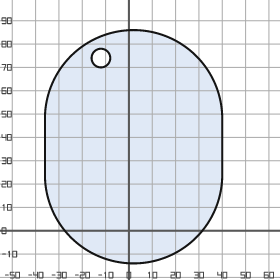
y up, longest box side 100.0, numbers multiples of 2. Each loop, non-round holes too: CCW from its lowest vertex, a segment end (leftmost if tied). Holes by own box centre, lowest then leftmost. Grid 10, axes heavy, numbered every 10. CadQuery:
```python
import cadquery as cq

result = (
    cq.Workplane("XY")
    .moveTo(-36.0, 24.0)
    .threePointArc((2.0, -14.0), (40.0, 24.0))
    .lineTo(40.0, 48.0)
    .threePointArc((2.0, 86.0), (-36.0, 48.0))
    .close()
    .moveTo(-12.0, 74.0)
    .circle(4.0)
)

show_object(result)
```